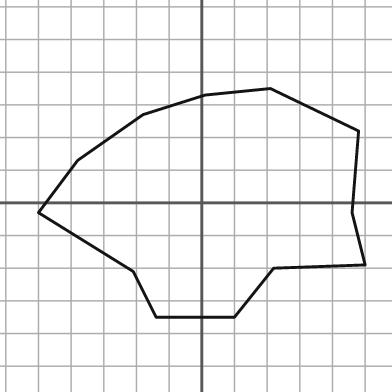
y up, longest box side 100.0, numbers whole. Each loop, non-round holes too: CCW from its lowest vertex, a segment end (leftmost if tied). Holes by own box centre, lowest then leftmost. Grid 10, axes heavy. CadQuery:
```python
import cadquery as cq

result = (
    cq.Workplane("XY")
    .moveTo(-14.0, -35.0)
    .lineTo(10.0, -35.0)
    .lineTo(22.0, -20.0)
    .lineTo(50.0, -19.0)
    .lineTo(46.0, -3.0)
    .lineTo(48.0, 22.0)
    .lineTo(21.0, 35.0)
    .lineTo(1.0, 33.0)
    .lineTo(-18.0, 27.0)
    .lineTo(-38.0, 13.0)
    .lineTo(-50.0, -3.0)
    .lineTo(-21.0, -21.0)
    .close()
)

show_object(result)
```